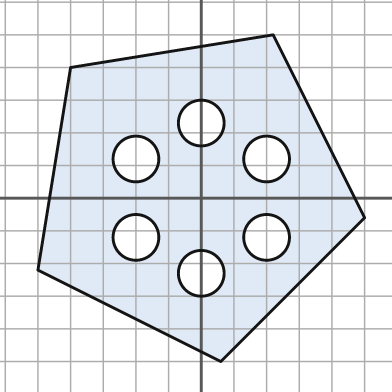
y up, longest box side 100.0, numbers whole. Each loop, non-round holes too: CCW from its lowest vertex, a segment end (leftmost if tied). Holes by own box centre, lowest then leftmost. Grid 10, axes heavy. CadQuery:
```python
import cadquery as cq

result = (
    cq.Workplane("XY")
    .moveTo(6.0, -50.0)
    .lineTo(50.0, -6.0)
    .lineTo(22.0, 50.0)
    .lineTo(-40.0, 40.0)
    .lineTo(-50.0, -22.0)
    .close()
    .moveTo(0.0, -23.0)
    .circle(7.0)
    .moveTo(-20.0, -12.0)
    .circle(7.0)
    .moveTo(20.0, -12.0)
    .circle(7.0)
    .moveTo(-20.0, 12.0)
    .circle(7.0)
    .moveTo(20.0, 12.0)
    .circle(7.0)
    .moveTo(0.0, 23.0)
    .circle(7.0)
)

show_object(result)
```